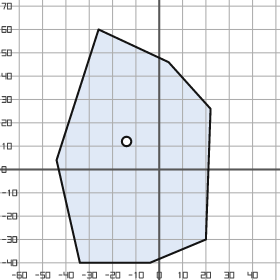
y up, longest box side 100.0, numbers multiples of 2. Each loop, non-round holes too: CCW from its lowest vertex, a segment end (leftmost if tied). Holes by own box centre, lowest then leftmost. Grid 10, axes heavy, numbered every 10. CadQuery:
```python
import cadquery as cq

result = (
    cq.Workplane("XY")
    .moveTo(-34.0, -40.0)
    .lineTo(-4.0, -40.0)
    .lineTo(20.0, -30.0)
    .lineTo(22.0, 26.0)
    .lineTo(4.0, 46.0)
    .lineTo(-26.0, 60.0)
    .lineTo(-44.0, 4.0)
    .close()
    .moveTo(-14.0, 12.0)
    .circle(2.0)
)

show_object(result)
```